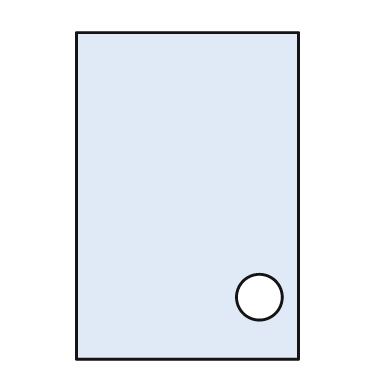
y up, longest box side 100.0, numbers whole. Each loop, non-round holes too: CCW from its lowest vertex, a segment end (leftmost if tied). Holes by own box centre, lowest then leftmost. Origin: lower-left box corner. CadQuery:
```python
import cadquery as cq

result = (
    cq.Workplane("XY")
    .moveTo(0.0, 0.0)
    .lineTo(68.0, 0.0)
    .lineTo(68.0, 100.0)
    .lineTo(0.0, 100.0)
    .close()
    .moveTo(56.0, 19.0)
    .circle(7.0)
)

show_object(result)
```